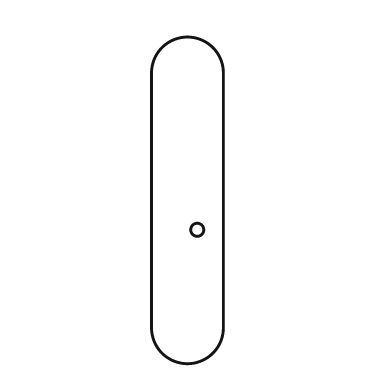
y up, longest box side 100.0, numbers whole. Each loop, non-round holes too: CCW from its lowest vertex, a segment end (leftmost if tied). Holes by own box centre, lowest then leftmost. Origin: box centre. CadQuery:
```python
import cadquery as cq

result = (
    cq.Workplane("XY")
    .moveTo(-11.0, -39.0)
    .threePointArc((0.0, -50.0), (11.0, -39.0))
    .lineTo(11.0, 39.0)
    .threePointArc((0.0, 50.0), (-11.0, 39.0))
    .close()
    .moveTo(3.0, -9.0)
    .circle(2.0)
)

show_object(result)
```